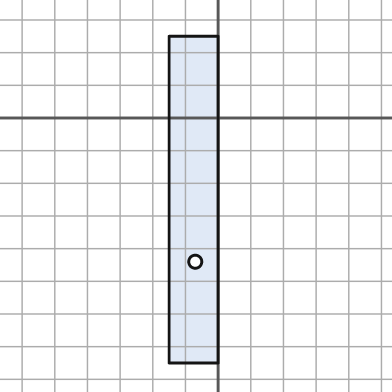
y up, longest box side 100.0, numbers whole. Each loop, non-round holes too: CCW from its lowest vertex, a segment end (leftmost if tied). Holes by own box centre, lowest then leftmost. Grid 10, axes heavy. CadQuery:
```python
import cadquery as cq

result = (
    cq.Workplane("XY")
    .moveTo(-15.0, -75.0)
    .lineTo(0.0, -75.0)
    .lineTo(0.0, 25.0)
    .lineTo(-15.0, 25.0)
    .close()
    .moveTo(-7.0, -44.0)
    .circle(2.0)
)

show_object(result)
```